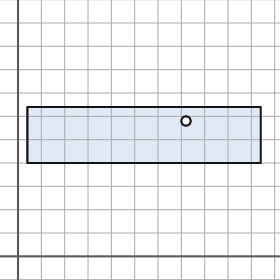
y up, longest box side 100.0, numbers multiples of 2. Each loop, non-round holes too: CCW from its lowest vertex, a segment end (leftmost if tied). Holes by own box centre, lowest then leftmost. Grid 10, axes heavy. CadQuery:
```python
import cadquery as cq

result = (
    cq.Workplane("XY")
    .moveTo(4.0, 40.0)
    .lineTo(104.0, 40.0)
    .lineTo(104.0, 64.0)
    .lineTo(4.0, 64.0)
    .close()
    .moveTo(72.0, 58.0)
    .circle(2.0)
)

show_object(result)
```